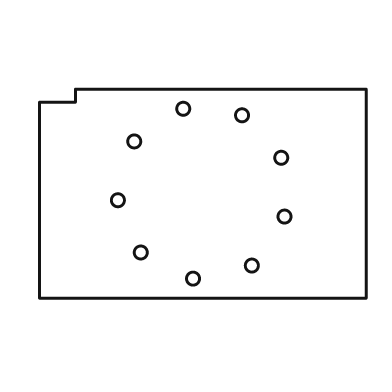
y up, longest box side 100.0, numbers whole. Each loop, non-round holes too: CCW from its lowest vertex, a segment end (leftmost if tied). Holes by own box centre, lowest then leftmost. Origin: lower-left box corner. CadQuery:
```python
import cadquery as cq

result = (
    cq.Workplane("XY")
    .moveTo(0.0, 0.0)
    .lineTo(100.0, 0.0)
    .lineTo(100.0, 64.0)
    .lineTo(11.0, 64.0)
    .lineTo(11.0, 60.0)
    .lineTo(0.0, 60.0)
    .close()
    .moveTo(47.0, 6.0)
    .circle(2.0)
    .moveTo(65.0, 10.0)
    .circle(2.0)
    .moveTo(31.0, 14.0)
    .circle(2.0)
    .moveTo(75.0, 25.0)
    .circle(2.0)
    .moveTo(24.0, 30.0)
    .circle(2.0)
    .moveTo(74.0, 43.0)
    .circle(2.0)
    .moveTo(29.0, 48.0)
    .circle(2.0)
    .moveTo(62.0, 56.0)
    .circle(2.0)
    .moveTo(44.0, 58.0)
    .circle(2.0)
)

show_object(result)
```